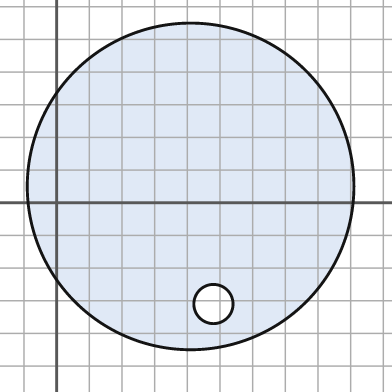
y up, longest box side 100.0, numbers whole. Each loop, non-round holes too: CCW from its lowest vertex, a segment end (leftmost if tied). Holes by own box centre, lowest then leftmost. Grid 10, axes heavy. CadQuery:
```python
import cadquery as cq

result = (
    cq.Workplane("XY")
    .moveTo(41.0, 5.0)
    .circle(50.0)
    .moveTo(48.0, -31.0)
    .circle(6.0)
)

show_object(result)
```